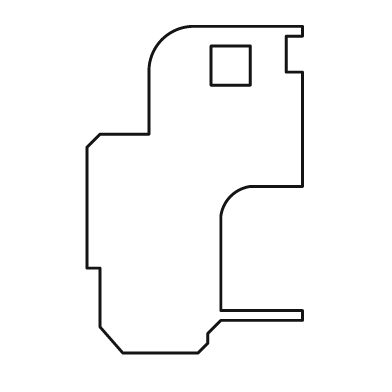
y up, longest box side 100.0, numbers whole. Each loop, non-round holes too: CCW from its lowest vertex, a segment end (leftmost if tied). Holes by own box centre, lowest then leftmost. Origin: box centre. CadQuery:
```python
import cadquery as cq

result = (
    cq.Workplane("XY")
    .moveTo(-22.0, -50.0)
    .lineTo(1.0, -50.0)
    .lineTo(4.0, -47.0)
    .lineTo(4.0, -44.0)
    .lineTo(8.0, -40.0)
    .lineTo(33.0, -40.0)
    .lineTo(33.0, -37.0)
    .lineTo(8.0, -37.0)
    .lineTo(8.0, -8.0)
    .threePointArc((11.0, -2.0), (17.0, 1.0))
    .lineTo(33.0, 1.0)
    .lineTo(33.0, 36.0)
    .lineTo(28.0, 36.0)
    .lineTo(28.0, 47.0)
    .lineTo(33.0, 47.0)
    .lineTo(33.0, 50.0)
    .lineTo(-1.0, 50.0)
    .threePointArc((-10.0, 46.0), (-14.0, 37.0))
    .lineTo(-14.0, 17.0)
    .lineTo(-29.0, 17.0)
    .lineTo(-33.0, 13.0)
    .lineTo(-33.0, -24.0)
    .lineTo(-29.0, -24.0)
    .lineTo(-29.0, -42.0)
    .close()
    .moveTo(5.0, 32.0)
    .lineTo(17.0, 32.0)
    .lineTo(17.0, 44.0)
    .lineTo(5.0, 44.0)
    .close()
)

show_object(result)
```